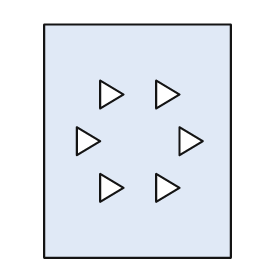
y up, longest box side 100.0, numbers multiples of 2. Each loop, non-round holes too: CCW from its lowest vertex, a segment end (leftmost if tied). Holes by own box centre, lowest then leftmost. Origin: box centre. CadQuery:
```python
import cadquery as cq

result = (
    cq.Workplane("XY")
    .moveTo(-40.0, -50.0)
    .lineTo(40.0, -50.0)
    .lineTo(40.0, 50.0)
    .lineTo(-40.0, 50.0)
    .close()
    .moveTo(-16.0, -26.0)
    .lineTo(-6.0, -20.0)
    .lineTo(-16.0, -14.0)
    .close()
    .moveTo(8.0, -26.0)
    .lineTo(18.0, -20.0)
    .lineTo(8.0, -14.0)
    .close()
    .moveTo(-26.0, -6.0)
    .lineTo(-16.0, 0.0)
    .lineTo(-26.0, 6.0)
    .close()
    .moveTo(18.0, -6.0)
    .lineTo(28.0, 0.0)
    .lineTo(18.0, 6.0)
    .close()
    .moveTo(-16.0, 14.0)
    .lineTo(-6.0, 20.0)
    .lineTo(-16.0, 26.0)
    .close()
    .moveTo(8.0, 14.0)
    .lineTo(18.0, 20.0)
    .lineTo(8.0, 26.0)
    .close()
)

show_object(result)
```